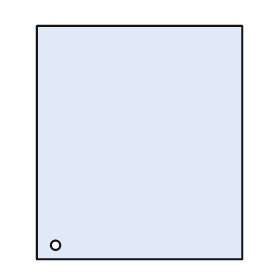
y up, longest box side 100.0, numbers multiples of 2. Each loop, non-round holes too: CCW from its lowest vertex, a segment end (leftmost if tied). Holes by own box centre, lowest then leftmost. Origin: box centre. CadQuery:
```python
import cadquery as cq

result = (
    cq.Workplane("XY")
    .moveTo(-44.0, -50.0)
    .lineTo(44.0, -50.0)
    .lineTo(44.0, 50.0)
    .lineTo(-44.0, 50.0)
    .close()
    .moveTo(-36.0, -44.0)
    .circle(2.0)
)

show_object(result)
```